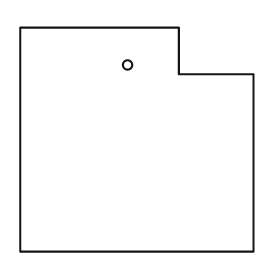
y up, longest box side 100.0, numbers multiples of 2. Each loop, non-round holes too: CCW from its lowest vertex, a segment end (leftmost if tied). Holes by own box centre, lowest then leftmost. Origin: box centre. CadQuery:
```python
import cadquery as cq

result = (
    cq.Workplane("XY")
    .moveTo(-50.0, -48.0)
    .lineTo(50.0, -48.0)
    .lineTo(50.0, 28.0)
    .lineTo(18.0, 28.0)
    .lineTo(18.0, 48.0)
    .lineTo(-50.0, 48.0)
    .close()
    .moveTo(-4.0, 32.0)
    .circle(2.0)
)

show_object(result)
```